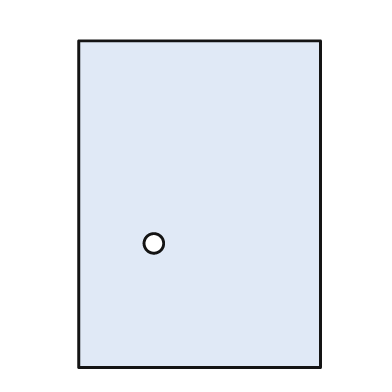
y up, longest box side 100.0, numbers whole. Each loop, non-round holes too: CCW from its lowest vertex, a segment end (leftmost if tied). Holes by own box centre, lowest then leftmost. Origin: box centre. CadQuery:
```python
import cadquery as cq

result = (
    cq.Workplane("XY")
    .moveTo(-37.0, -50.0)
    .lineTo(37.0, -50.0)
    .lineTo(37.0, 50.0)
    .lineTo(-37.0, 50.0)
    .close()
    .moveTo(-14.0, -12.0)
    .circle(3.0)
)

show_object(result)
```